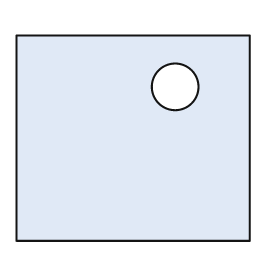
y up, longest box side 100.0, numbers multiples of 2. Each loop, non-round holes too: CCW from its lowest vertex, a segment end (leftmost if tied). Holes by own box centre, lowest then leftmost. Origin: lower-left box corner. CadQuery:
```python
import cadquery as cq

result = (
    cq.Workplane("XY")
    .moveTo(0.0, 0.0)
    .lineTo(100.0, 0.0)
    .lineTo(100.0, 88.0)
    .lineTo(0.0, 88.0)
    .close()
    .moveTo(68.0, 66.0)
    .circle(10.0)
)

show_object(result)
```